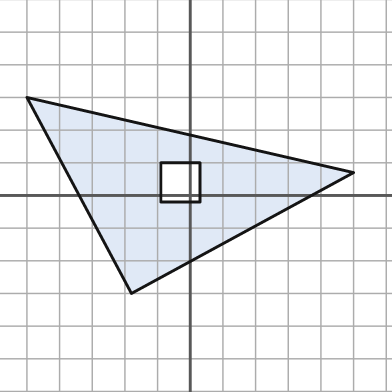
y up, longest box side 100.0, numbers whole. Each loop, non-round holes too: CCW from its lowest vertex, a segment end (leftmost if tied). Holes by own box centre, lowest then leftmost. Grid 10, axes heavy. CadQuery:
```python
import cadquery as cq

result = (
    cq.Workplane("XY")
    .moveTo(-18.0, -30.0)
    .lineTo(50.0, 7.0)
    .lineTo(-50.0, 30.0)
    .close()
    .moveTo(-9.0, -2.0)
    .lineTo(3.0, -2.0)
    .lineTo(3.0, 10.0)
    .lineTo(-9.0, 10.0)
    .close()
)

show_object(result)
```